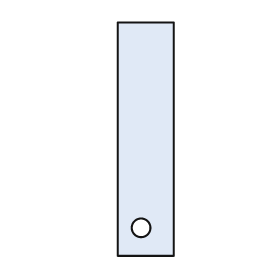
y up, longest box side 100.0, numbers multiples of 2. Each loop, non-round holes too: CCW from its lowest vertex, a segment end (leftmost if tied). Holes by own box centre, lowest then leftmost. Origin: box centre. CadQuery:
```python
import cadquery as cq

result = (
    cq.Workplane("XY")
    .moveTo(-12.0, -50.0)
    .lineTo(12.0, -50.0)
    .lineTo(12.0, 50.0)
    .lineTo(-12.0, 50.0)
    .close()
    .moveTo(-2.0, -38.0)
    .circle(4.0)
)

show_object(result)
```